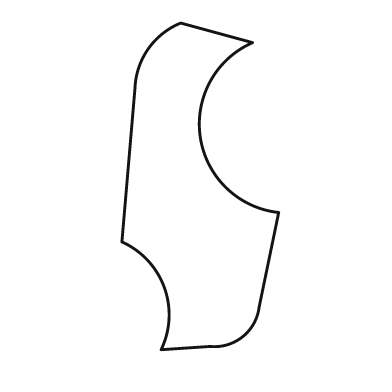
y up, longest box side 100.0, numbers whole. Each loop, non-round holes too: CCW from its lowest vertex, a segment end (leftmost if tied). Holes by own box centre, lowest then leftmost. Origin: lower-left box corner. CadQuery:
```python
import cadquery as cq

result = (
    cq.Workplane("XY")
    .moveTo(12.0, 0.0)
    .lineTo(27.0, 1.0)
    .threePointArc((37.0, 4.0), (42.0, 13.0))
    .lineTo(48.0, 42.0)
    .threePointArc((24.0, 65.0), (40.0, 94.0))
    .lineTo(18.0, 100.0)
    .threePointArc((8.0, 92.0), (4.0, 80.0))
    .lineTo(0.0, 33.0)
    .threePointArc((13.0, 19.0), (12.0, 0.0))
    .close()
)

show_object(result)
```